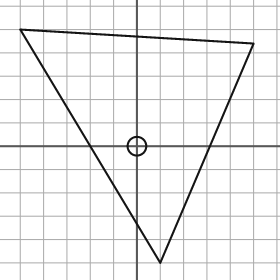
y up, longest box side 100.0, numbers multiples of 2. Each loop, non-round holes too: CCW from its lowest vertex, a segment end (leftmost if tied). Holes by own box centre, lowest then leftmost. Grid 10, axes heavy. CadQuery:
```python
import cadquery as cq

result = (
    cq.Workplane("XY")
    .moveTo(10.0, -50.0)
    .lineTo(50.0, 44.0)
    .lineTo(-50.0, 50.0)
    .close()
    .moveTo(0.0, 0.0)
    .circle(4.0)
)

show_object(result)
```